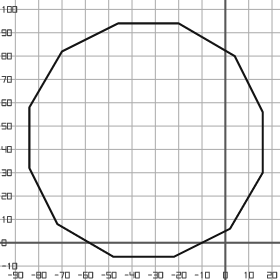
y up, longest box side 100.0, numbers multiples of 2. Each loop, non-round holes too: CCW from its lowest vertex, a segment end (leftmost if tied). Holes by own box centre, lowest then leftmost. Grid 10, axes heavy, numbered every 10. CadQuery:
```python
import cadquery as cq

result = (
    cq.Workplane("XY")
    .moveTo(-48.0, -6.0)
    .lineTo(-22.0, -6.0)
    .lineTo(2.0, 6.0)
    .lineTo(16.0, 30.0)
    .lineTo(16.0, 56.0)
    .lineTo(4.0, 80.0)
    .lineTo(-20.0, 94.0)
    .lineTo(-46.0, 94.0)
    .lineTo(-70.0, 82.0)
    .lineTo(-84.0, 58.0)
    .lineTo(-84.0, 32.0)
    .lineTo(-72.0, 8.0)
    .close()
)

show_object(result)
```